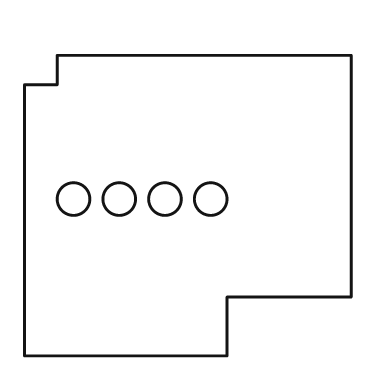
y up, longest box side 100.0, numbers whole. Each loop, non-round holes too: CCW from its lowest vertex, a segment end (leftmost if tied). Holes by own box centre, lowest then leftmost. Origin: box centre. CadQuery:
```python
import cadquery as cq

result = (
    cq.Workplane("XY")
    .moveTo(-50.0, -46.0)
    .lineTo(12.0, -46.0)
    .lineTo(12.0, -28.0)
    .lineTo(50.0, -28.0)
    .lineTo(50.0, 46.0)
    .lineTo(-40.0, 46.0)
    .lineTo(-40.0, 37.0)
    .lineTo(-50.0, 37.0)
    .close()
    .moveTo(-35.0, 2.0)
    .circle(5.0)
    .moveTo(-21.0, 2.0)
    .circle(5.0)
    .moveTo(-7.0, 2.0)
    .circle(5.0)
    .moveTo(7.0, 2.0)
    .circle(5.0)
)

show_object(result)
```